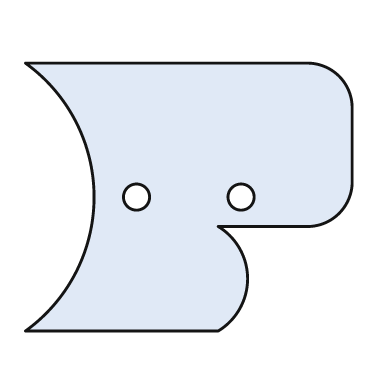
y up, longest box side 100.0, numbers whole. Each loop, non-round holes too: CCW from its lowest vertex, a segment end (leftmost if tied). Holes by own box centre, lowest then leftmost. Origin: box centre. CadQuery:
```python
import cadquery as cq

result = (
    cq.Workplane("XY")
    .moveTo(-50.0, -41.0)
    .lineTo(9.0, -41.0)
    .threePointArc((18.0, -25.0), (9.0, -9.0))
    .lineTo(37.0, -9.0)
    .threePointArc((46.0, -5.0), (50.0, 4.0))
    .lineTo(50.0, 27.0)
    .threePointArc((46.0, 37.0), (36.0, 41.0))
    .lineTo(-50.0, 41.0)
    .threePointArc((-29.0, 0.0), (-50.0, -41.0))
    .close()
    .moveTo(-16.0, 0.0)
    .circle(4.0)
    .moveTo(16.0, 0.0)
    .circle(4.0)
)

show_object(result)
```